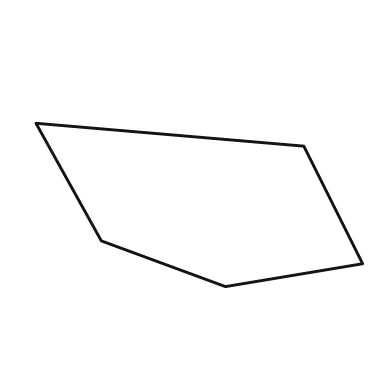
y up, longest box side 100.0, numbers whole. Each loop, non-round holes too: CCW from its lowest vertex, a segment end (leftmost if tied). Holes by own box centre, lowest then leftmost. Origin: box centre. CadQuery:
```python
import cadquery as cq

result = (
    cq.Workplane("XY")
    .moveTo(8.0, -25.0)
    .lineTo(50.0, -18.0)
    .lineTo(32.0, 18.0)
    .lineTo(-50.0, 25.0)
    .lineTo(-30.0, -11.0)
    .close()
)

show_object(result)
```